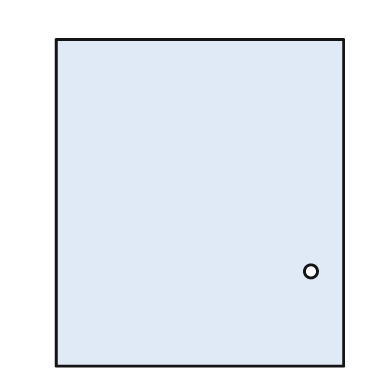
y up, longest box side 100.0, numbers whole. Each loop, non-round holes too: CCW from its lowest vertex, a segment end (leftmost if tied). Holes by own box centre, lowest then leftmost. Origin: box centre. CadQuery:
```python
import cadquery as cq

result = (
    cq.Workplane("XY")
    .moveTo(-44.0, -50.0)
    .lineTo(44.0, -50.0)
    .lineTo(44.0, 50.0)
    .lineTo(-44.0, 50.0)
    .close()
    .moveTo(34.0, -21.0)
    .circle(2.0)
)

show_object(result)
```